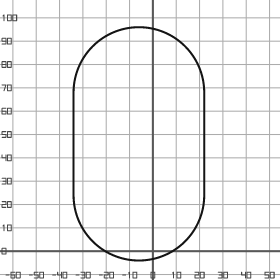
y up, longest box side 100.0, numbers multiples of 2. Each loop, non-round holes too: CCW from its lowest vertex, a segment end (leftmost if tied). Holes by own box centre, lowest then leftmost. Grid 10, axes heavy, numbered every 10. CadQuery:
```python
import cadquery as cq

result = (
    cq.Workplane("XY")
    .moveTo(-34.0, 24.0)
    .threePointArc((-6.0, -4.0), (22.0, 24.0))
    .lineTo(22.0, 68.0)
    .threePointArc((-6.0, 96.0), (-34.0, 68.0))
    .close()
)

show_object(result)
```